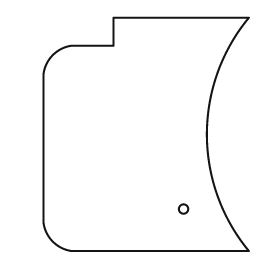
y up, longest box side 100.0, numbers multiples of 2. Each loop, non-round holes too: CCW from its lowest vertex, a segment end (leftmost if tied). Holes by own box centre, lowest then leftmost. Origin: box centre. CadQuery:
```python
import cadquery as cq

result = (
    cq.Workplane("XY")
    .moveTo(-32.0, -50.0)
    .lineTo(44.0, -50.0)
    .threePointArc((26.0, 0.0), (44.0, 50.0))
    .lineTo(-14.0, 50.0)
    .lineTo(-14.0, 38.0)
    .lineTo(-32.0, 38.0)
    .threePointArc((-40.0, 34.0), (-44.0, 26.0))
    .lineTo(-44.0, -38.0)
    .threePointArc((-40.0, -46.0), (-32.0, -50.0))
    .close()
    .moveTo(16.0, -32.0)
    .circle(2.0)
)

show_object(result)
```